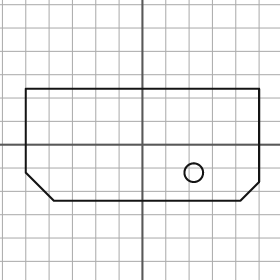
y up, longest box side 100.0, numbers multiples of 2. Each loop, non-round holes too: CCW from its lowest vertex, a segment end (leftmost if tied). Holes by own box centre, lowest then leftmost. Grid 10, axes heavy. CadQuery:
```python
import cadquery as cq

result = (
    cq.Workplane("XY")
    .moveTo(-38.0, -24.0)
    .lineTo(42.0, -24.0)
    .lineTo(50.0, -16.0)
    .lineTo(50.0, 24.0)
    .lineTo(-50.0, 24.0)
    .lineTo(-50.0, -12.0)
    .close()
    .moveTo(22.0, -12.0)
    .circle(4.0)
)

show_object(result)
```